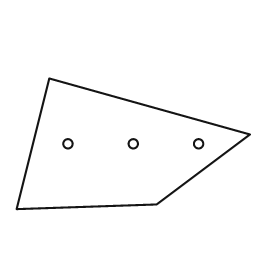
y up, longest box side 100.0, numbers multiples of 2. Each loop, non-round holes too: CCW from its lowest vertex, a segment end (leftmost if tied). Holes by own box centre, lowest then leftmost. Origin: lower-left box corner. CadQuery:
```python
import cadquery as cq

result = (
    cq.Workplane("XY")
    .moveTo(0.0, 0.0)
    .lineTo(60.0, 2.0)
    .lineTo(100.0, 32.0)
    .lineTo(14.0, 56.0)
    .close()
    .moveTo(22.0, 28.0)
    .circle(2.0)
    .moveTo(50.0, 28.0)
    .circle(2.0)
    .moveTo(78.0, 28.0)
    .circle(2.0)
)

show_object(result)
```